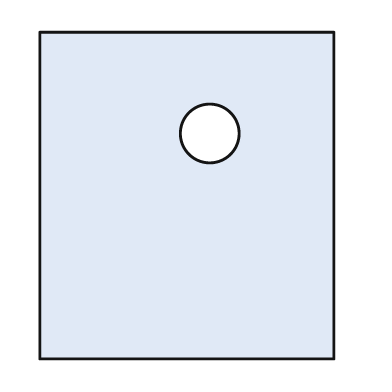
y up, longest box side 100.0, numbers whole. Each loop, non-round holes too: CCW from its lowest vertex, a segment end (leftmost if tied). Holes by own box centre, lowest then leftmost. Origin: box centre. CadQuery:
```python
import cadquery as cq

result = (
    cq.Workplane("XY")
    .moveTo(-45.0, -50.0)
    .lineTo(45.0, -50.0)
    .lineTo(45.0, 50.0)
    .lineTo(-45.0, 50.0)
    .close()
    .moveTo(7.0, 19.0)
    .circle(9.0)
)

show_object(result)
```